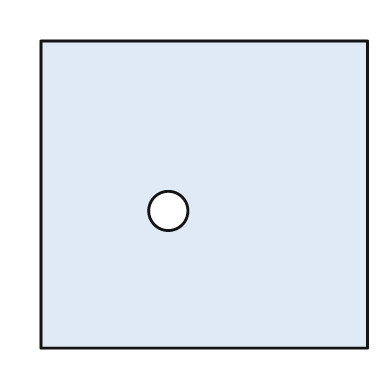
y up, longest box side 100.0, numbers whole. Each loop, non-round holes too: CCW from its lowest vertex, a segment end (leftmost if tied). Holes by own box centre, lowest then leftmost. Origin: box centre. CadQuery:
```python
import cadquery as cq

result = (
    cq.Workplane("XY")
    .moveTo(-50.0, -47.0)
    .lineTo(50.0, -47.0)
    .lineTo(50.0, 47.0)
    .lineTo(-50.0, 47.0)
    .close()
    .moveTo(-11.0, -5.0)
    .circle(6.0)
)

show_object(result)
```